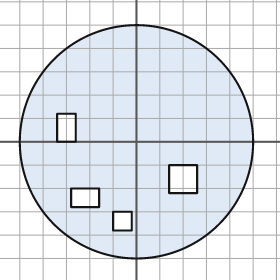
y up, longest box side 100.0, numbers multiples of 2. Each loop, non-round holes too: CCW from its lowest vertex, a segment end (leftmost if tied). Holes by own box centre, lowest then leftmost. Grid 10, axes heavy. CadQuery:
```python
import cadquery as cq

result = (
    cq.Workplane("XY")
    .moveTo(0.0, 0.0)
    .circle(50.0)
    .moveTo(-10.0, -38.0)
    .lineTo(-2.0, -38.0)
    .lineTo(-2.0, -30.0)
    .lineTo(-10.0, -30.0)
    .close()
    .moveTo(-28.0, -28.0)
    .lineTo(-16.0, -28.0)
    .lineTo(-16.0, -20.0)
    .lineTo(-28.0, -20.0)
    .close()
    .moveTo(14.0, -22.0)
    .lineTo(26.0, -22.0)
    .lineTo(26.0, -10.0)
    .lineTo(14.0, -10.0)
    .close()
    .moveTo(-34.0, 0.0)
    .lineTo(-26.0, 0.0)
    .lineTo(-26.0, 12.0)
    .lineTo(-34.0, 12.0)
    .close()
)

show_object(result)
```